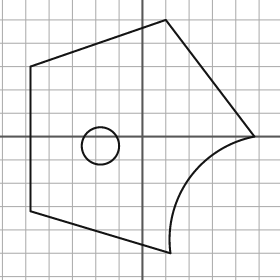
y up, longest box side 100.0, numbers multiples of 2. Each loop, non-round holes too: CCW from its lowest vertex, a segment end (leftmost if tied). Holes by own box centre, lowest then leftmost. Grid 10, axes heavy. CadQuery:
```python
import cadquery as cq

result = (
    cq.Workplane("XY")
    .moveTo(12.0, -50.0)
    .threePointArc((20.0, -18.0), (48.0, 0.0))
    .lineTo(10.0, 50.0)
    .lineTo(-48.0, 30.0)
    .lineTo(-48.0, -32.0)
    .close()
    .moveTo(-18.0, -4.0)
    .circle(8.0)
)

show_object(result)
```